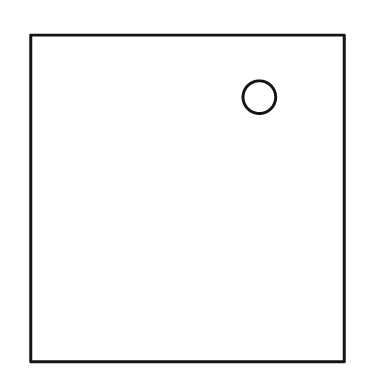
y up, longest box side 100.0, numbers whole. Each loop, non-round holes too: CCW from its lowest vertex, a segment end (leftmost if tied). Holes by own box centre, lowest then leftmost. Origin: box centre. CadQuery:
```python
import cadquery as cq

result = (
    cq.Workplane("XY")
    .moveTo(-48.0, -50.0)
    .lineTo(48.0, -50.0)
    .lineTo(48.0, 50.0)
    .lineTo(-48.0, 50.0)
    .close()
    .moveTo(22.0, 31.0)
    .circle(5.0)
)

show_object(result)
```